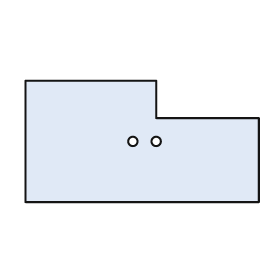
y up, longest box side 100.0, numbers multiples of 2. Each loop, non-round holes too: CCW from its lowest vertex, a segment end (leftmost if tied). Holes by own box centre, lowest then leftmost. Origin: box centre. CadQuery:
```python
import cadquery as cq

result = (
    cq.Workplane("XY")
    .moveTo(-50.0, -26.0)
    .lineTo(50.0, -26.0)
    .lineTo(50.0, 10.0)
    .lineTo(6.0, 10.0)
    .lineTo(6.0, 26.0)
    .lineTo(-50.0, 26.0)
    .close()
    .moveTo(-4.0, 0.0)
    .circle(2.0)
    .moveTo(6.0, 0.0)
    .circle(2.0)
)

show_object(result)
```